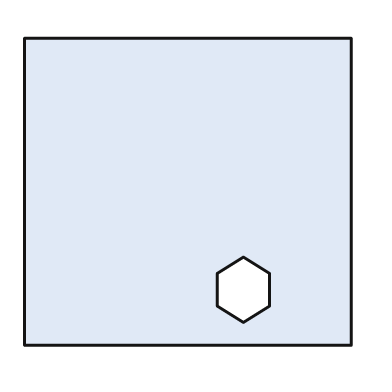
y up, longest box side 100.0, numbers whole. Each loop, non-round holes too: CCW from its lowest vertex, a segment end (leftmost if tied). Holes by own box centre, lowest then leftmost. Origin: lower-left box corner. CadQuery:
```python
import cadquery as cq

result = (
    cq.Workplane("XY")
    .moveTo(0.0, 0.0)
    .lineTo(100.0, 0.0)
    .lineTo(100.0, 94.0)
    .lineTo(0.0, 94.0)
    .close()
    .moveTo(67.0, 7.0)
    .lineTo(75.0, 12.0)
    .lineTo(75.0, 22.0)
    .lineTo(67.0, 27.0)
    .lineTo(59.0, 22.0)
    .lineTo(59.0, 12.0)
    .close()
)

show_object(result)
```